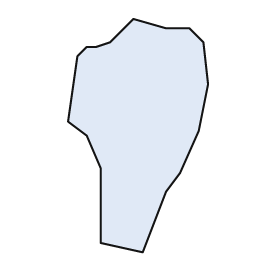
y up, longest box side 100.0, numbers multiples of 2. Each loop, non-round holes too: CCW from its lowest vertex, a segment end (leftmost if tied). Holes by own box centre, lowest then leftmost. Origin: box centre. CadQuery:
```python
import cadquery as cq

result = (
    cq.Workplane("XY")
    .moveTo(2.0, -50.0)
    .lineTo(12.0, -24.0)
    .lineTo(18.0, -16.0)
    .lineTo(26.0, 2.0)
    .lineTo(30.0, 22.0)
    .lineTo(28.0, 40.0)
    .lineTo(22.0, 46.0)
    .lineTo(12.0, 46.0)
    .lineTo(-2.0, 50.0)
    .lineTo(-12.0, 40.0)
    .lineTo(-18.0, 38.0)
    .lineTo(-22.0, 38.0)
    .lineTo(-26.0, 34.0)
    .lineTo(-30.0, 6.0)
    .lineTo(-22.0, 0.0)
    .lineTo(-16.0, -14.0)
    .lineTo(-16.0, -46.0)
    .close()
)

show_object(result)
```